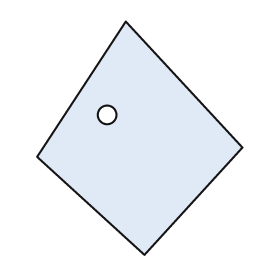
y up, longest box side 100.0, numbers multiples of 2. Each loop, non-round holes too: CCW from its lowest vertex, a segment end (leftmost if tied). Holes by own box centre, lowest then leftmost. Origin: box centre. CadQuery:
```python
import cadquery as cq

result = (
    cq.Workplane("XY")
    .moveTo(2.0, -50.0)
    .lineTo(44.0, -4.0)
    .lineTo(-6.0, 50.0)
    .lineTo(-44.0, -8.0)
    .close()
    .moveTo(-14.0, 10.0)
    .circle(4.0)
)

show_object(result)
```